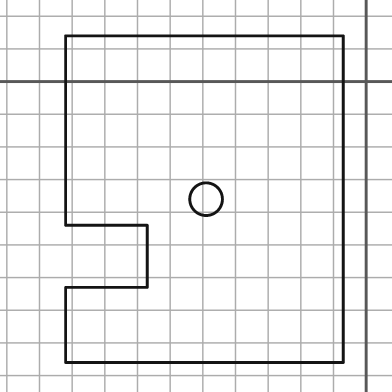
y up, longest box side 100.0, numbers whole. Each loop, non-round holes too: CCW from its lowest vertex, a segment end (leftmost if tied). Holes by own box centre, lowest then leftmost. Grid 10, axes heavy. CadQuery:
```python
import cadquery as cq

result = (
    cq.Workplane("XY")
    .moveTo(-92.0, -86.0)
    .lineTo(-7.0, -86.0)
    .lineTo(-7.0, 14.0)
    .lineTo(-92.0, 14.0)
    .lineTo(-92.0, -44.0)
    .lineTo(-67.0, -44.0)
    .lineTo(-67.0, -63.0)
    .lineTo(-92.0, -63.0)
    .close()
    .moveTo(-49.0, -36.0)
    .circle(5.0)
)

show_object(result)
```